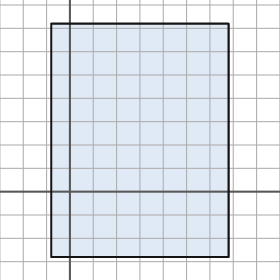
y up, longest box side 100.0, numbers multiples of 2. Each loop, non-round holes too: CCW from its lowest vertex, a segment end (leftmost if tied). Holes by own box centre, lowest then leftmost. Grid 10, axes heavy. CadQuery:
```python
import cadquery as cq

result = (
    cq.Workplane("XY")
    .moveTo(-8.0, -28.0)
    .lineTo(68.0, -28.0)
    .lineTo(68.0, 72.0)
    .lineTo(-8.0, 72.0)
    .close()
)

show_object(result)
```